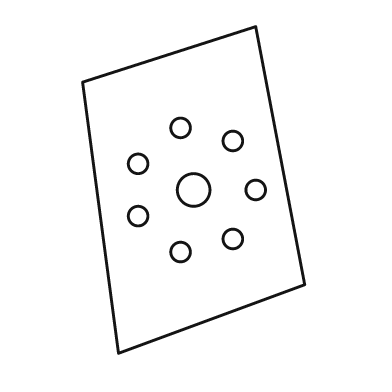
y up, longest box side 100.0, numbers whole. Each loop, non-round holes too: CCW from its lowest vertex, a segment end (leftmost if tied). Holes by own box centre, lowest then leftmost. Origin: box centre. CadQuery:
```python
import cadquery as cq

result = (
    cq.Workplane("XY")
    .moveTo(-23.0, -50.0)
    .lineTo(34.0, -29.0)
    .lineTo(19.0, 50.0)
    .lineTo(-34.0, 33.0)
    .close()
    .moveTo(-4.0, -19.0)
    .circle(3.0)
    .moveTo(12.0, -15.0)
    .circle(3.0)
    .moveTo(-17.0, -8.0)
    .circle(3.0)
    .moveTo(0.0, 0.0)
    .circle(5.0)
    .moveTo(19.0, 0.0)
    .circle(3.0)
    .moveTo(-17.0, 8.0)
    .circle(3.0)
    .moveTo(12.0, 15.0)
    .circle(3.0)
    .moveTo(-4.0, 19.0)
    .circle(3.0)
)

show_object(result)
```